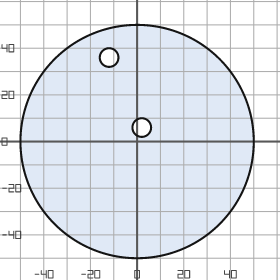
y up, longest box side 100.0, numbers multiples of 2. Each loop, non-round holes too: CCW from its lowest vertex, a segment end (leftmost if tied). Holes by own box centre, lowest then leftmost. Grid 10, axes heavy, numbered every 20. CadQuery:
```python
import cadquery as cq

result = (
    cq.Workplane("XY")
    .moveTo(0.0, 0.0)
    .circle(50.0)
    .moveTo(2.0, 6.0)
    .circle(4.0)
    .moveTo(-12.0, 36.0)
    .circle(4.0)
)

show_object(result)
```